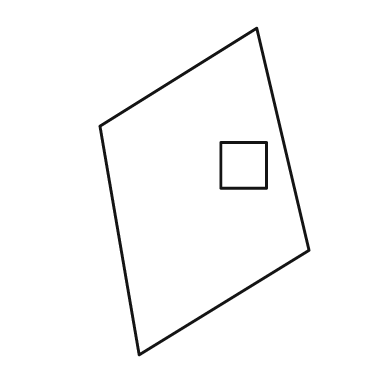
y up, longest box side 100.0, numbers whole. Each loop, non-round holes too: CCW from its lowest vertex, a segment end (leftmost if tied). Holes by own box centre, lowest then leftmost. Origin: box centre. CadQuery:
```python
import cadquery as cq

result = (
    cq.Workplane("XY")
    .moveTo(-20.0, -50.0)
    .lineTo(32.0, -18.0)
    .lineTo(16.0, 50.0)
    .lineTo(-32.0, 20.0)
    .close()
    .moveTo(5.0, 1.0)
    .lineTo(19.0, 1.0)
    .lineTo(19.0, 15.0)
    .lineTo(5.0, 15.0)
    .close()
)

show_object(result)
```